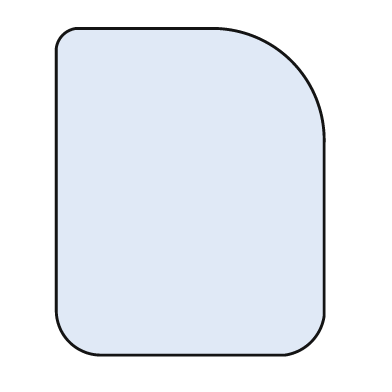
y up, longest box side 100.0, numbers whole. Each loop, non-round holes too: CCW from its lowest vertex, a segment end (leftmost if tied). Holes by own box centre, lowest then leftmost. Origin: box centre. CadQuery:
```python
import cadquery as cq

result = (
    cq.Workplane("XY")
    .moveTo(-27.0, -50.0)
    .lineTo(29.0, -50.0)
    .threePointArc((37.0, -46.0), (41.0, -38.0))
    .lineTo(41.0, 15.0)
    .threePointArc((31.0, 40.0), (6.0, 50.0))
    .lineTo(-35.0, 50.0)
    .threePointArc((-39.0, 48.0), (-41.0, 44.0))
    .lineTo(-41.0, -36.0)
    .threePointArc((-37.0, -46.0), (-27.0, -50.0))
    .close()
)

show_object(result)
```